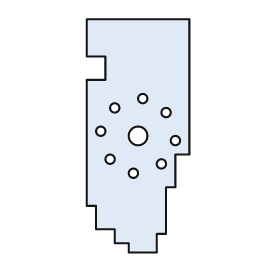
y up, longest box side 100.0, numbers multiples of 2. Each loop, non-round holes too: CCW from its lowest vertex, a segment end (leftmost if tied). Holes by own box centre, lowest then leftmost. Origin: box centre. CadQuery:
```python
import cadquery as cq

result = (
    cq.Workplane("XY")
    .moveTo(-4.0, -50.0)
    .lineTo(8.0, -50.0)
    .lineTo(8.0, -42.0)
    .lineTo(12.0, -42.0)
    .lineTo(12.0, -22.0)
    .lineTo(16.0, -22.0)
    .lineTo(16.0, -8.0)
    .lineTo(22.0, -8.0)
    .lineTo(22.0, 50.0)
    .lineTo(-22.0, 50.0)
    .lineTo(-22.0, 34.0)
    .lineTo(-14.0, 34.0)
    .lineTo(-14.0, 24.0)
    .lineTo(-22.0, 24.0)
    .lineTo(-22.0, -30.0)
    .lineTo(-18.0, -30.0)
    .lineTo(-18.0, -40.0)
    .lineTo(-10.0, -40.0)
    .lineTo(-10.0, -46.0)
    .lineTo(-4.0, -46.0)
    .close()
    .moveTo(-2.0, -16.0)
    .circle(2.0)
    .moveTo(10.0, -12.0)
    .circle(2.0)
    .moveTo(-12.0, -10.0)
    .circle(2.0)
    .moveTo(16.0, -2.0)
    .circle(2.0)
    .moveTo(0.0, 0.0)
    .circle(4.0)
    .moveTo(-16.0, 2.0)
    .circle(2.0)
    .moveTo(12.0, 10.0)
    .circle(2.0)
    .moveTo(-10.0, 12.0)
    .circle(2.0)
    .moveTo(2.0, 16.0)
    .circle(2.0)
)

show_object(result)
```